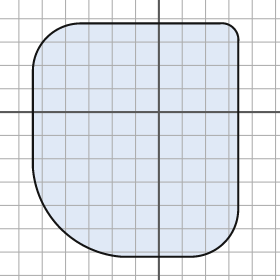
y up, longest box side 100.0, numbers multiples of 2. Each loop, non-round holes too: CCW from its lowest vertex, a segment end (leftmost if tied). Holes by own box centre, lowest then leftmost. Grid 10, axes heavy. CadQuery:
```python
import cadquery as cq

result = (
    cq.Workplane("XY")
    .moveTo(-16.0, -62.0)
    .lineTo(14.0, -62.0)
    .threePointArc((28.0, -56.0), (34.0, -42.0))
    .lineTo(34.0, 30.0)
    .threePointArc((32.0, 36.0), (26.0, 38.0))
    .lineTo(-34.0, 38.0)
    .threePointArc((-48.0, 32.0), (-54.0, 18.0))
    .lineTo(-54.0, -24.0)
    .threePointArc((-42.0, -50.0), (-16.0, -62.0))
    .close()
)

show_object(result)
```